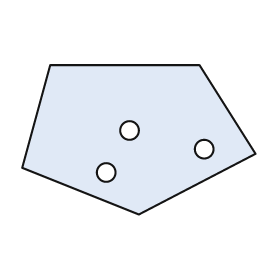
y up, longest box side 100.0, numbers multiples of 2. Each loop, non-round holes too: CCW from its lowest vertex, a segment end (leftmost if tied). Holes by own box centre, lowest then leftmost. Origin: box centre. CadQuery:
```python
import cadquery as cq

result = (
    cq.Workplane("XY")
    .moveTo(0.0, -32.0)
    .lineTo(50.0, -6.0)
    .lineTo(26.0, 32.0)
    .lineTo(-38.0, 32.0)
    .lineTo(-50.0, -12.0)
    .close()
    .moveTo(-14.0, -14.0)
    .circle(4.0)
    .moveTo(28.0, -4.0)
    .circle(4.0)
    .moveTo(-4.0, 4.0)
    .circle(4.0)
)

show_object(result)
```